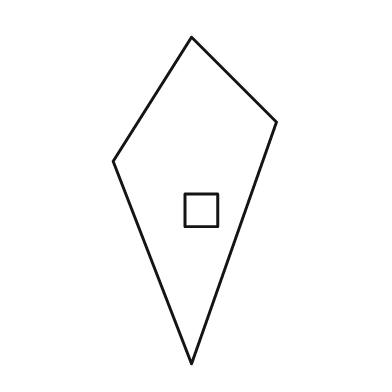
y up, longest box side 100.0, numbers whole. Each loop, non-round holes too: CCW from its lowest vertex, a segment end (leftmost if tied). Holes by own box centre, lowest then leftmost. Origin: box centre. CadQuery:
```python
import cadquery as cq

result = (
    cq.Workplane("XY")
    .moveTo(-1.0, -50.0)
    .lineTo(25.0, 24.0)
    .lineTo(-1.0, 50.0)
    .lineTo(-25.0, 12.0)
    .close()
    .moveTo(-3.0, -8.0)
    .lineTo(7.0, -8.0)
    .lineTo(7.0, 2.0)
    .lineTo(-3.0, 2.0)
    .close()
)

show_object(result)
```